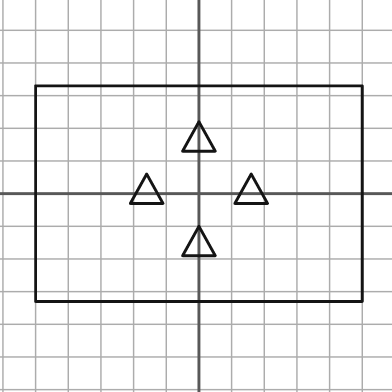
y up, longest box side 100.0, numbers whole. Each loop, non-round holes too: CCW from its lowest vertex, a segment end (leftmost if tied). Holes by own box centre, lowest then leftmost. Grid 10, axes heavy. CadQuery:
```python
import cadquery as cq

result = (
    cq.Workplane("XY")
    .moveTo(-50.0, -33.0)
    .lineTo(50.0, -33.0)
    .lineTo(50.0, 33.0)
    .lineTo(-50.0, 33.0)
    .close()
    .moveTo(-5.0, -19.0)
    .lineTo(5.0, -19.0)
    .lineTo(0.0, -10.0)
    .close()
    .moveTo(-21.0, -3.0)
    .lineTo(-11.0, -3.0)
    .lineTo(-16.0, 6.0)
    .close()
    .moveTo(11.0, -3.0)
    .lineTo(21.0, -3.0)
    .lineTo(16.0, 6.0)
    .close()
    .moveTo(-5.0, 13.0)
    .lineTo(5.0, 13.0)
    .lineTo(0.0, 22.0)
    .close()
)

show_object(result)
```